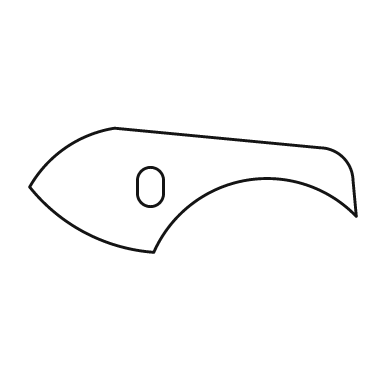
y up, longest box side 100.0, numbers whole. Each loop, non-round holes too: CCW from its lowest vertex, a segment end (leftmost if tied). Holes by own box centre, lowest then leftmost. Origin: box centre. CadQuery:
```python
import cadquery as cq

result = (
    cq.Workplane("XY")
    .moveTo(-12.0, -19.0)
    .threePointArc((16.0, 3.0), (50.0, -8.0))
    .lineTo(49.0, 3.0)
    .threePointArc((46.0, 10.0), (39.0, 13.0))
    .lineTo(-24.0, 19.0)
    .threePointArc((-39.0, 13.0), (-50.0, 1.0))
    .threePointArc((-33.0, -13.0), (-12.0, -19.0))
    .close()
    .moveTo(-17.0, -1.0)
    .threePointArc((-13.0, -5.0), (-9.0, -1.0))
    .lineTo(-9.0, 3.0)
    .threePointArc((-13.0, 7.0), (-17.0, 3.0))
    .close()
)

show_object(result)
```